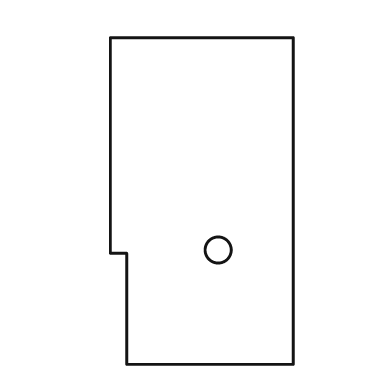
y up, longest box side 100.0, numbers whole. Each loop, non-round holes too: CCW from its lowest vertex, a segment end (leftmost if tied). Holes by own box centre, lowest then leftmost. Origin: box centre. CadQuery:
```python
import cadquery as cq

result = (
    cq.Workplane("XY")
    .moveTo(-23.0, -50.0)
    .lineTo(28.0, -50.0)
    .lineTo(28.0, 50.0)
    .lineTo(-28.0, 50.0)
    .lineTo(-28.0, -16.0)
    .lineTo(-23.0, -16.0)
    .close()
    .moveTo(5.0, -15.0)
    .circle(4.0)
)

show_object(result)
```